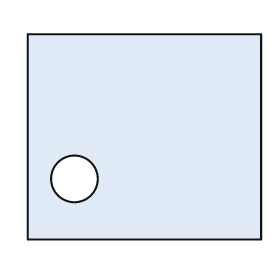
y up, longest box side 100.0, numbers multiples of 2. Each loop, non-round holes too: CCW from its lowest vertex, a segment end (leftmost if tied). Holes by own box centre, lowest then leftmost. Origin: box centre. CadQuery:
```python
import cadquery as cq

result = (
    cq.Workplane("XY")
    .moveTo(-50.0, -44.0)
    .lineTo(50.0, -44.0)
    .lineTo(50.0, 44.0)
    .lineTo(-50.0, 44.0)
    .close()
    .moveTo(-30.0, -18.0)
    .circle(10.0)
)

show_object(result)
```